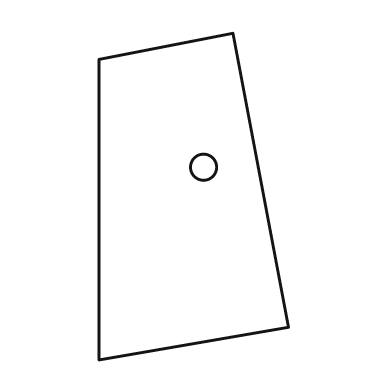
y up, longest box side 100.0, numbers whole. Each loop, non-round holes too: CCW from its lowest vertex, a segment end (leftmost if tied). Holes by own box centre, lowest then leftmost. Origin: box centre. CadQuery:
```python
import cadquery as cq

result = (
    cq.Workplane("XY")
    .moveTo(-29.0, -50.0)
    .lineTo(29.0, -40.0)
    .lineTo(12.0, 50.0)
    .lineTo(-29.0, 42.0)
    .close()
    .moveTo(3.0, 9.0)
    .circle(4.0)
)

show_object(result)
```